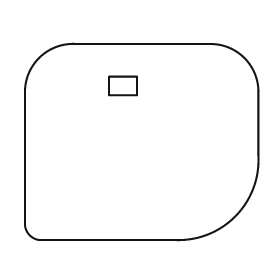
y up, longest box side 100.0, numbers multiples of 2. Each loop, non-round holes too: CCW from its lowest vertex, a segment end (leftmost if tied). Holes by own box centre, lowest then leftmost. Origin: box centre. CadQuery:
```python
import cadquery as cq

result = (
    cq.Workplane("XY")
    .moveTo(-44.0, -42.0)
    .lineTo(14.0, -42.0)
    .threePointArc((40.0, -32.0), (50.0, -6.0))
    .lineTo(50.0, 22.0)
    .threePointArc((44.0, 36.0), (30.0, 42.0))
    .lineTo(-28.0, 42.0)
    .threePointArc((-44.0, 36.0), (-50.0, 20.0))
    .lineTo(-50.0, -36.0)
    .threePointArc((-48.0, -40.0), (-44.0, -42.0))
    .close()
    .moveTo(-14.0, 20.0)
    .lineTo(-2.0, 20.0)
    .lineTo(-2.0, 28.0)
    .lineTo(-14.0, 28.0)
    .close()
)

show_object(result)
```